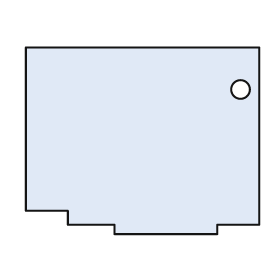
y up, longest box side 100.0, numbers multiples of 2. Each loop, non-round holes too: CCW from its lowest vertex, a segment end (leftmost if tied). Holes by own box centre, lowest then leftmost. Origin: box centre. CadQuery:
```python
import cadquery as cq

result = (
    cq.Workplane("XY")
    .moveTo(-12.0, -40.0)
    .lineTo(32.0, -40.0)
    .lineTo(32.0, -36.0)
    .lineTo(50.0, -36.0)
    .lineTo(50.0, 40.0)
    .lineTo(-50.0, 40.0)
    .lineTo(-50.0, -30.0)
    .lineTo(-32.0, -30.0)
    .lineTo(-32.0, -36.0)
    .lineTo(-12.0, -36.0)
    .close()
    .moveTo(42.0, 22.0)
    .circle(4.0)
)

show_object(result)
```